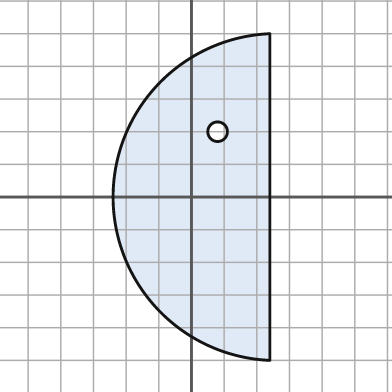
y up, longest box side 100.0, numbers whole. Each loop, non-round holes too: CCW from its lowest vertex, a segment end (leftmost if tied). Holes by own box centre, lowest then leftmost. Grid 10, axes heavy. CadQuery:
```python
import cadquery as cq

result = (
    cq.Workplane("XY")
    .moveTo(24.0, -50.0)
    .lineTo(24.0, 50.0)
    .threePointArc((-24.0, 0.0), (24.0, -50.0))
    .close()
    .moveTo(8.0, 20.0)
    .circle(3.0)
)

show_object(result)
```